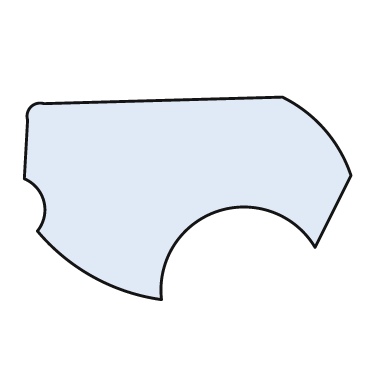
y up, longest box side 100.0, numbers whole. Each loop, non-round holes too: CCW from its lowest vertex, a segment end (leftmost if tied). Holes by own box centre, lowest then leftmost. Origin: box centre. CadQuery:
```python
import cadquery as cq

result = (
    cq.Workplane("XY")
    .moveTo(-8.0, -31.0)
    .threePointArc((9.0, -4.0), (39.0, -15.0))
    .lineTo(50.0, 7.0)
    .threePointArc((42.0, 21.0), (29.0, 31.0))
    .lineTo(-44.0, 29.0)
    .threePointArc((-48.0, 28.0), (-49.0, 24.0))
    .lineTo(-50.0, 6.0)
    .threePointArc((-44.0, -1.0), (-46.0, -10.0))
    .threePointArc((-29.0, -24.0), (-8.0, -31.0))
    .close()
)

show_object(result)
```